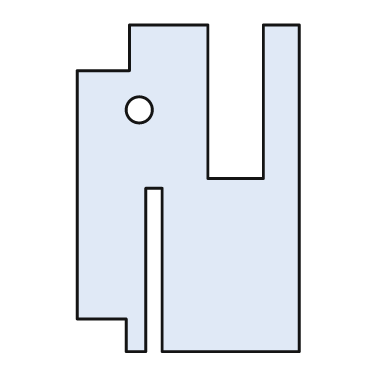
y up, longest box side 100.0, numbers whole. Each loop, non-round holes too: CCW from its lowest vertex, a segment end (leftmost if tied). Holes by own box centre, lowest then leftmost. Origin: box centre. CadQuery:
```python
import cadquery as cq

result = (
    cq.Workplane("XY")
    .moveTo(-19.0, -50.0)
    .lineTo(-13.0, -50.0)
    .lineTo(-13.0, 0.0)
    .lineTo(-8.0, 0.0)
    .lineTo(-8.0, -50.0)
    .lineTo(34.0, -50.0)
    .lineTo(34.0, 50.0)
    .lineTo(23.0, 50.0)
    .lineTo(23.0, 3.0)
    .lineTo(6.0, 3.0)
    .lineTo(6.0, 50.0)
    .lineTo(-18.0, 50.0)
    .lineTo(-18.0, 36.0)
    .lineTo(-34.0, 36.0)
    .lineTo(-34.0, -40.0)
    .lineTo(-19.0, -40.0)
    .close()
    .moveTo(-15.0, 24.0)
    .circle(4.0)
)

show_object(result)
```